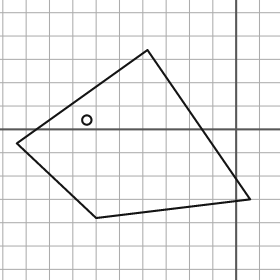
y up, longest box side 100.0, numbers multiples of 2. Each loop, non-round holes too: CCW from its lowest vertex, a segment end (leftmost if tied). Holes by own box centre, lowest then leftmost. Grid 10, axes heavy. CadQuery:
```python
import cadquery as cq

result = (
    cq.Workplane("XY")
    .moveTo(-60.0, -38.0)
    .lineTo(6.0, -30.0)
    .lineTo(-38.0, 34.0)
    .lineTo(-94.0, -6.0)
    .close()
    .moveTo(-64.0, 4.0)
    .circle(2.0)
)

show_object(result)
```